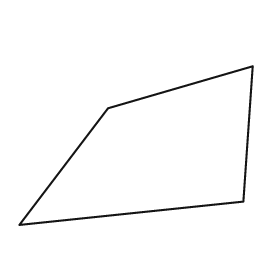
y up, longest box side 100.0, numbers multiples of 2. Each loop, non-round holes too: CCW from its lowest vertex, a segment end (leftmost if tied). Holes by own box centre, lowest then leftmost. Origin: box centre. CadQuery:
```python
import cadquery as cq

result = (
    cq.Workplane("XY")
    .moveTo(-50.0, -34.0)
    .lineTo(46.0, -24.0)
    .lineTo(50.0, 34.0)
    .lineTo(-12.0, 16.0)
    .close()
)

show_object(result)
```